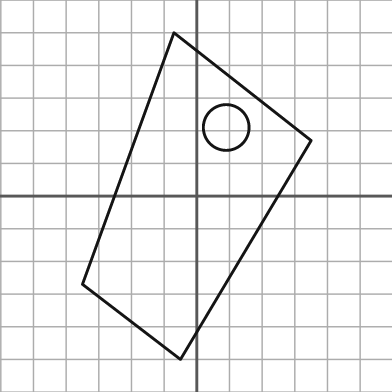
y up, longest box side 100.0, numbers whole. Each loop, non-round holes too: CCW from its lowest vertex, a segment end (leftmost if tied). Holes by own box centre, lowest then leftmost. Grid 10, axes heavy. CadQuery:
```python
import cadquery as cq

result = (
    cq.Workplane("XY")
    .moveTo(-5.0, -50.0)
    .lineTo(35.0, 17.0)
    .lineTo(-7.0, 50.0)
    .lineTo(-35.0, -27.0)
    .close()
    .moveTo(9.0, 21.0)
    .circle(7.0)
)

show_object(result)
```